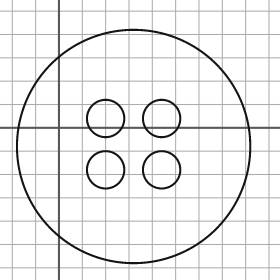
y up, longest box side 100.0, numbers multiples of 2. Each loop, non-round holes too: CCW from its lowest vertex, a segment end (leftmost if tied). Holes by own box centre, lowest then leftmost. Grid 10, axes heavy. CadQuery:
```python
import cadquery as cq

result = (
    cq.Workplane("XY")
    .moveTo(32.0, -8.0)
    .circle(50.0)
    .moveTo(20.0, -18.0)
    .circle(8.0)
    .moveTo(44.0, -18.0)
    .circle(8.0)
    .moveTo(20.0, 4.0)
    .circle(8.0)
    .moveTo(44.0, 4.0)
    .circle(8.0)
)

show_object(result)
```